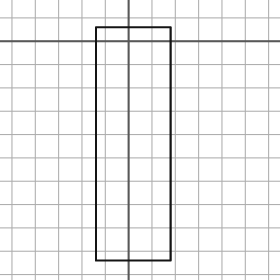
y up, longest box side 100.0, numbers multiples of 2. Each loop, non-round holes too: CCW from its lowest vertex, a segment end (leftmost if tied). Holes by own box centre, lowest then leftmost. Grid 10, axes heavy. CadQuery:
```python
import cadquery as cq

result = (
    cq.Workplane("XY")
    .moveTo(-14.0, -94.0)
    .lineTo(18.0, -94.0)
    .lineTo(18.0, 6.0)
    .lineTo(-14.0, 6.0)
    .close()
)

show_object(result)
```